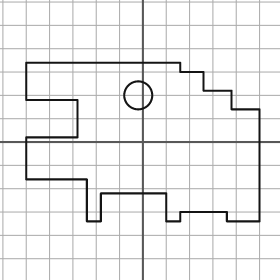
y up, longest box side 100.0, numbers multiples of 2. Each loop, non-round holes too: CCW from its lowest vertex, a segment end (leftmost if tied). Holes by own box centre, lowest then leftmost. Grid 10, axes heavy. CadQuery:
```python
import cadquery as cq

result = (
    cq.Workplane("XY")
    .moveTo(-24.0, -34.0)
    .lineTo(-18.0, -34.0)
    .lineTo(-18.0, -22.0)
    .lineTo(10.0, -22.0)
    .lineTo(10.0, -34.0)
    .lineTo(16.0, -34.0)
    .lineTo(16.0, -30.0)
    .lineTo(36.0, -30.0)
    .lineTo(36.0, -34.0)
    .lineTo(50.0, -34.0)
    .lineTo(50.0, 14.0)
    .lineTo(38.0, 14.0)
    .lineTo(38.0, 22.0)
    .lineTo(26.0, 22.0)
    .lineTo(26.0, 30.0)
    .lineTo(16.0, 30.0)
    .lineTo(16.0, 34.0)
    .lineTo(-50.0, 34.0)
    .lineTo(-50.0, 18.0)
    .lineTo(-28.0, 18.0)
    .lineTo(-28.0, 2.0)
    .lineTo(-50.0, 2.0)
    .lineTo(-50.0, -16.0)
    .lineTo(-24.0, -16.0)
    .close()
    .moveTo(-2.0, 20.0)
    .circle(6.0)
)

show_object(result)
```